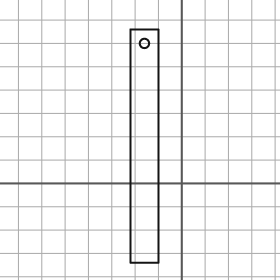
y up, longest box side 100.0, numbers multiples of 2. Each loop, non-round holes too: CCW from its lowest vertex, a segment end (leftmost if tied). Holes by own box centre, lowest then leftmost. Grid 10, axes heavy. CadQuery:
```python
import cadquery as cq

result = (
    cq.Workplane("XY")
    .moveTo(-22.0, -34.0)
    .lineTo(-10.0, -34.0)
    .lineTo(-10.0, 66.0)
    .lineTo(-22.0, 66.0)
    .close()
    .moveTo(-16.0, 60.0)
    .circle(2.0)
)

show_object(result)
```